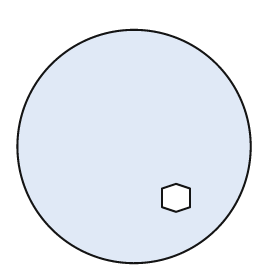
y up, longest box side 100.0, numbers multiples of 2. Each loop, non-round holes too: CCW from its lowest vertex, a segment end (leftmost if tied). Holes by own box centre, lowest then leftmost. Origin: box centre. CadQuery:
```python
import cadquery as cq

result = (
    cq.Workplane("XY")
    .moveTo(0.0, 0.0)
    .circle(50.0)
    .moveTo(18.0, -28.0)
    .lineTo(24.0, -26.0)
    .lineTo(24.0, -18.0)
    .lineTo(18.0, -16.0)
    .lineTo(12.0, -18.0)
    .lineTo(12.0, -26.0)
    .close()
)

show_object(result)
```